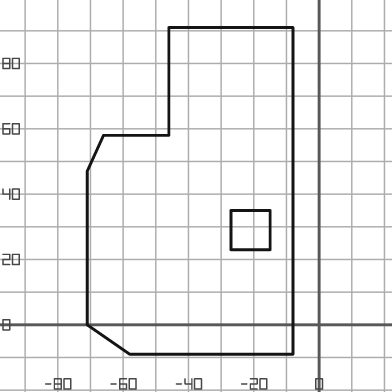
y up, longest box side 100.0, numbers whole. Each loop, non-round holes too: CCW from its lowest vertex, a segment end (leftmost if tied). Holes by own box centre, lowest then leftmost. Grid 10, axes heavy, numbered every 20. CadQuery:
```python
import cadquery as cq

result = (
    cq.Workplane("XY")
    .moveTo(-58.0, -9.0)
    .lineTo(-8.0, -9.0)
    .lineTo(-8.0, 91.0)
    .lineTo(-46.0, 91.0)
    .lineTo(-46.0, 58.0)
    .lineTo(-66.0, 58.0)
    .lineTo(-71.0, 47.0)
    .lineTo(-71.0, 0.0)
    .close()
    .moveTo(-27.0, 23.0)
    .lineTo(-15.0, 23.0)
    .lineTo(-15.0, 35.0)
    .lineTo(-27.0, 35.0)
    .close()
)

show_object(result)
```